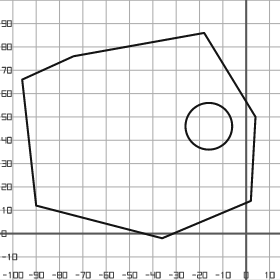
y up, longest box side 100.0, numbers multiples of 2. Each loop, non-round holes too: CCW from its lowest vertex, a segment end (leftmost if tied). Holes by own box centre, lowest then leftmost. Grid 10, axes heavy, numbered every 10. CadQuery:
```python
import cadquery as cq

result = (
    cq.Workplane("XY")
    .moveTo(-36.0, -2.0)
    .lineTo(2.0, 14.0)
    .lineTo(4.0, 50.0)
    .lineTo(-18.0, 86.0)
    .lineTo(-74.0, 76.0)
    .lineTo(-96.0, 66.0)
    .lineTo(-90.0, 12.0)
    .close()
    .moveTo(-16.0, 46.0)
    .circle(10.0)
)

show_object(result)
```